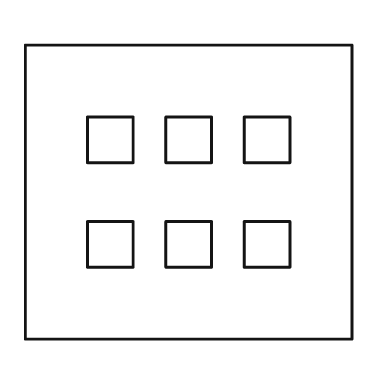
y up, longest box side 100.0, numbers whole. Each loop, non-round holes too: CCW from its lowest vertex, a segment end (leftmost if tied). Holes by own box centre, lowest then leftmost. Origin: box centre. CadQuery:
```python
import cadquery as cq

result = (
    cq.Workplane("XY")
    .moveTo(-50.0, -45.0)
    .lineTo(50.0, -45.0)
    .lineTo(50.0, 45.0)
    .lineTo(-50.0, 45.0)
    .close()
    .moveTo(-31.0, -23.0)
    .lineTo(-17.0, -23.0)
    .lineTo(-17.0, -9.0)
    .lineTo(-31.0, -9.0)
    .close()
    .moveTo(-7.0, -23.0)
    .lineTo(7.0, -23.0)
    .lineTo(7.0, -9.0)
    .lineTo(-7.0, -9.0)
    .close()
    .moveTo(17.0, -23.0)
    .lineTo(31.0, -23.0)
    .lineTo(31.0, -9.0)
    .lineTo(17.0, -9.0)
    .close()
    .moveTo(-31.0, 9.0)
    .lineTo(-17.0, 9.0)
    .lineTo(-17.0, 23.0)
    .lineTo(-31.0, 23.0)
    .close()
    .moveTo(-7.0, 9.0)
    .lineTo(7.0, 9.0)
    .lineTo(7.0, 23.0)
    .lineTo(-7.0, 23.0)
    .close()
    .moveTo(17.0, 9.0)
    .lineTo(31.0, 9.0)
    .lineTo(31.0, 23.0)
    .lineTo(17.0, 23.0)
    .close()
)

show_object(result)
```